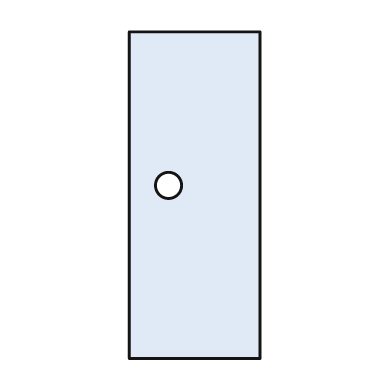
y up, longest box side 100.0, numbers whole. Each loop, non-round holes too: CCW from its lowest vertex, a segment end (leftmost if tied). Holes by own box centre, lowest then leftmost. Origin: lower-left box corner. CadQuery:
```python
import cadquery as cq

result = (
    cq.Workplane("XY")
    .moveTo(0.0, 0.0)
    .lineTo(40.0, 0.0)
    .lineTo(40.0, 100.0)
    .lineTo(0.0, 100.0)
    .close()
    .moveTo(12.0, 53.0)
    .circle(4.0)
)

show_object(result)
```